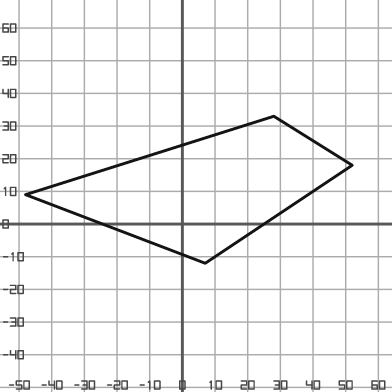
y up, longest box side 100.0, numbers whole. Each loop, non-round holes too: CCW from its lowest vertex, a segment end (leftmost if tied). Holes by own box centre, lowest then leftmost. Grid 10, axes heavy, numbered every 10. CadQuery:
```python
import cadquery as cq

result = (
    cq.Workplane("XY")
    .moveTo(7.0, -12.0)
    .lineTo(52.0, 18.0)
    .lineTo(28.0, 33.0)
    .lineTo(-48.0, 9.0)
    .close()
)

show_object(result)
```